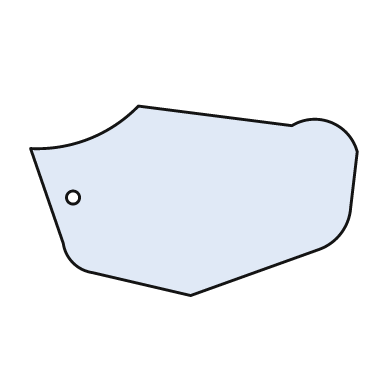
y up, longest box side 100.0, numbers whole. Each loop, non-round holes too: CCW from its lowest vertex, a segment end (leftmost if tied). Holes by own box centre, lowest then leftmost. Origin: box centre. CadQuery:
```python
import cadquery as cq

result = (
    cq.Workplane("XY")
    .moveTo(-1.0, -29.0)
    .lineTo(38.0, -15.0)
    .threePointArc((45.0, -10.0), (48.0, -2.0))
    .lineTo(50.0, 15.0)
    .threePointArc((42.0, 24.0), (30.0, 23.0))
    .lineTo(-17.0, 29.0)
    .threePointArc((-32.0, 19.0), (-50.0, 16.0))
    .lineTo(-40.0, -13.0)
    .threePointArc((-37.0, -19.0), (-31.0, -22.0))
    .close()
    .moveTo(-37.0, 1.0)
    .circle(2.0)
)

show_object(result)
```